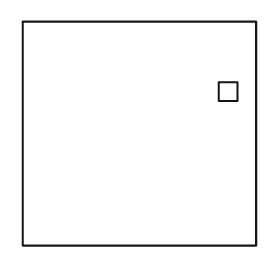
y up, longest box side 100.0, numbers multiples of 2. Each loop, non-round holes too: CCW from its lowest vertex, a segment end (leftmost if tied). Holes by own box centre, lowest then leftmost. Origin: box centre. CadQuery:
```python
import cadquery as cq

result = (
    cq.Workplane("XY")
    .moveTo(-50.0, -48.0)
    .lineTo(50.0, -48.0)
    .lineTo(50.0, 48.0)
    .lineTo(-50.0, 48.0)
    .close()
    .moveTo(34.0, 14.0)
    .lineTo(42.0, 14.0)
    .lineTo(42.0, 22.0)
    .lineTo(34.0, 22.0)
    .close()
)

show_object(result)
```